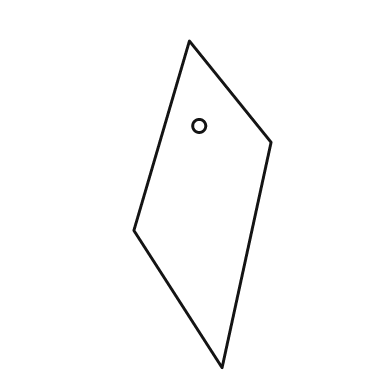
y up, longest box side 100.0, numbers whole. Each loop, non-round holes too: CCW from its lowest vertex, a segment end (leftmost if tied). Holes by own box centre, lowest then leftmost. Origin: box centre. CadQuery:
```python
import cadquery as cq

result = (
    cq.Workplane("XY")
    .moveTo(6.0, -50.0)
    .lineTo(21.0, 19.0)
    .lineTo(-4.0, 50.0)
    .lineTo(-21.0, -8.0)
    .close()
    .moveTo(-1.0, 24.0)
    .circle(2.0)
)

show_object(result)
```